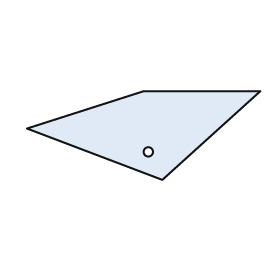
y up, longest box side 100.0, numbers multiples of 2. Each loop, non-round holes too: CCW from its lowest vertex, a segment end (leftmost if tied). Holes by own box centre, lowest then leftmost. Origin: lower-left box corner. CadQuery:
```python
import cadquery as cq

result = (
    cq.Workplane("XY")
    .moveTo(58.0, 0.0)
    .lineTo(100.0, 38.0)
    .lineTo(50.0, 38.0)
    .lineTo(0.0, 22.0)
    .close()
    .moveTo(52.0, 12.0)
    .circle(2.0)
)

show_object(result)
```